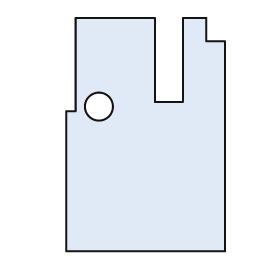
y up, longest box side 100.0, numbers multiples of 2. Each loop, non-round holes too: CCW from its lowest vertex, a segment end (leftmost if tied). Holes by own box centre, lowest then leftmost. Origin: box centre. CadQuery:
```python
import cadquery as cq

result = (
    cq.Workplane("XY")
    .moveTo(-34.0, -50.0)
    .lineTo(34.0, -50.0)
    .lineTo(34.0, 40.0)
    .lineTo(26.0, 40.0)
    .lineTo(26.0, 50.0)
    .lineTo(16.0, 50.0)
    .lineTo(16.0, 14.0)
    .lineTo(4.0, 14.0)
    .lineTo(4.0, 50.0)
    .lineTo(-30.0, 50.0)
    .lineTo(-30.0, 10.0)
    .lineTo(-34.0, 10.0)
    .close()
    .moveTo(-20.0, 12.0)
    .circle(6.0)
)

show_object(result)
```